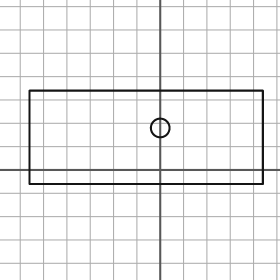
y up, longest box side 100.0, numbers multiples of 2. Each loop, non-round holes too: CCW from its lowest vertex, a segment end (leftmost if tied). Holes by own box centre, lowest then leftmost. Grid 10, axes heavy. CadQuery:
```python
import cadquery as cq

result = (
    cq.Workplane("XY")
    .moveTo(-56.0, -6.0)
    .lineTo(44.0, -6.0)
    .lineTo(44.0, 34.0)
    .lineTo(-56.0, 34.0)
    .close()
    .moveTo(0.0, 18.0)
    .circle(4.0)
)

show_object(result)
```